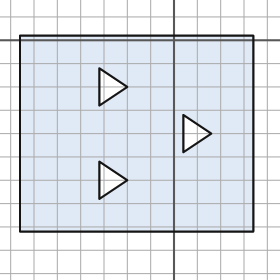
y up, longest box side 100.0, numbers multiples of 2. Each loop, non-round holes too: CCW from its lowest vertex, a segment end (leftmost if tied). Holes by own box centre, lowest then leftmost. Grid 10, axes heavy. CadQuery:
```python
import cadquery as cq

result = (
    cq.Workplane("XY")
    .moveTo(-66.0, -82.0)
    .lineTo(34.0, -82.0)
    .lineTo(34.0, 2.0)
    .lineTo(-66.0, 2.0)
    .close()
    .moveTo(-32.0, -68.0)
    .lineTo(-20.0, -60.0)
    .lineTo(-32.0, -52.0)
    .close()
    .moveTo(4.0, -48.0)
    .lineTo(16.0, -40.0)
    .lineTo(4.0, -32.0)
    .close()
    .moveTo(-32.0, -28.0)
    .lineTo(-20.0, -20.0)
    .lineTo(-32.0, -12.0)
    .close()
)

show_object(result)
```